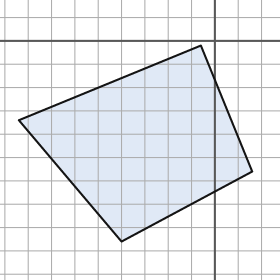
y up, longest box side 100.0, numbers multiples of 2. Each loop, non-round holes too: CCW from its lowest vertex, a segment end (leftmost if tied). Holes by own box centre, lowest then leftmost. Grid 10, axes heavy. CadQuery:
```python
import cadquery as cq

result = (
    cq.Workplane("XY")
    .moveTo(-40.0, -86.0)
    .lineTo(16.0, -56.0)
    .lineTo(-6.0, -2.0)
    .lineTo(-84.0, -34.0)
    .close()
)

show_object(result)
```